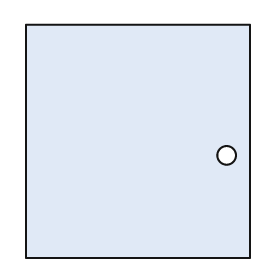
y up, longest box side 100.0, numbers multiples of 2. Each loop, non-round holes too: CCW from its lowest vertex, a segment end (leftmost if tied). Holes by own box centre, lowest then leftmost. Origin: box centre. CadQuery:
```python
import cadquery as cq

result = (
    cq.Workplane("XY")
    .moveTo(-48.0, -50.0)
    .lineTo(48.0, -50.0)
    .lineTo(48.0, 50.0)
    .lineTo(-48.0, 50.0)
    .close()
    .moveTo(38.0, -6.0)
    .circle(4.0)
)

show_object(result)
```